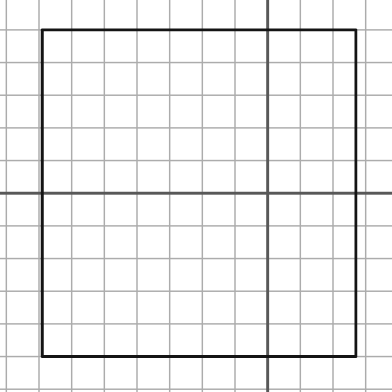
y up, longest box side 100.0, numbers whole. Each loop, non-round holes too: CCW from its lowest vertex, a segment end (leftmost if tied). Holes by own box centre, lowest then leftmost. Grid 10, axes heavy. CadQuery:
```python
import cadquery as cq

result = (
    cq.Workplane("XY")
    .moveTo(-69.0, -50.0)
    .lineTo(27.0, -50.0)
    .lineTo(27.0, 50.0)
    .lineTo(-69.0, 50.0)
    .close()
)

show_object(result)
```